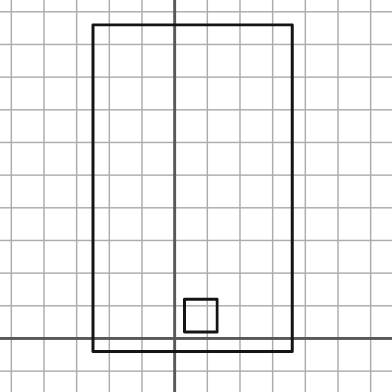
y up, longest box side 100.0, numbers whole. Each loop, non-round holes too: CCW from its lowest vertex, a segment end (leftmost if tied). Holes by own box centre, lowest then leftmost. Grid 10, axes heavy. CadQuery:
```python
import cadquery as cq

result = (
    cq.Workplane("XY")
    .moveTo(-25.0, -4.0)
    .lineTo(36.0, -4.0)
    .lineTo(36.0, 96.0)
    .lineTo(-25.0, 96.0)
    .close()
    .moveTo(3.0, 2.0)
    .lineTo(13.0, 2.0)
    .lineTo(13.0, 12.0)
    .lineTo(3.0, 12.0)
    .close()
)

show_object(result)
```